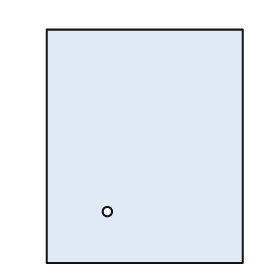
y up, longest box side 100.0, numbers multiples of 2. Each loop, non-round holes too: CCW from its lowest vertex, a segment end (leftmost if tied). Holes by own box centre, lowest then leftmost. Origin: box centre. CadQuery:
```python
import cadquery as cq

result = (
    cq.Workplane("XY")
    .moveTo(-42.0, -50.0)
    .lineTo(42.0, -50.0)
    .lineTo(42.0, 50.0)
    .lineTo(-42.0, 50.0)
    .close()
    .moveTo(-16.0, -28.0)
    .circle(2.0)
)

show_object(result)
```